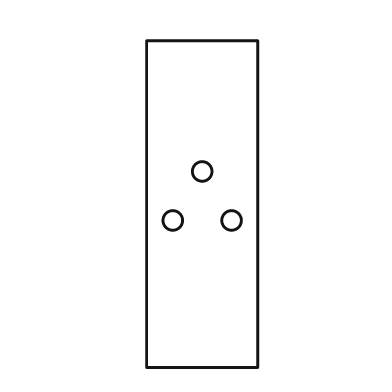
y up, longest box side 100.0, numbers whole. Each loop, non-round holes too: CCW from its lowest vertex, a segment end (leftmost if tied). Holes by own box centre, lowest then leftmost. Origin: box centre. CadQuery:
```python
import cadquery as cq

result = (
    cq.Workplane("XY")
    .moveTo(-17.0, -50.0)
    .lineTo(17.0, -50.0)
    .lineTo(17.0, 50.0)
    .lineTo(-17.0, 50.0)
    .close()
    .moveTo(-9.0, -5.0)
    .circle(3.0)
    .moveTo(9.0, -5.0)
    .circle(3.0)
    .moveTo(0.0, 10.0)
    .circle(3.0)
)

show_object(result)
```